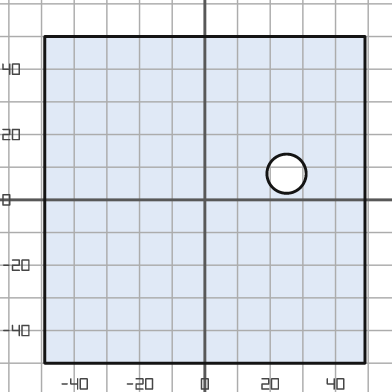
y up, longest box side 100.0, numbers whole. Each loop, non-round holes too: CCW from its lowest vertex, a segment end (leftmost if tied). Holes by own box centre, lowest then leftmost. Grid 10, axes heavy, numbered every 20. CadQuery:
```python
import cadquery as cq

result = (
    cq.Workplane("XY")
    .moveTo(-49.0, -50.0)
    .lineTo(49.0, -50.0)
    .lineTo(49.0, 50.0)
    .lineTo(-49.0, 50.0)
    .close()
    .moveTo(25.0, 8.0)
    .circle(6.0)
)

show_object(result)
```